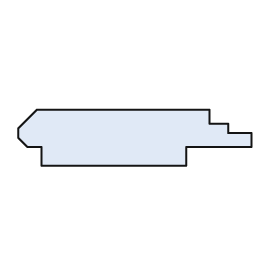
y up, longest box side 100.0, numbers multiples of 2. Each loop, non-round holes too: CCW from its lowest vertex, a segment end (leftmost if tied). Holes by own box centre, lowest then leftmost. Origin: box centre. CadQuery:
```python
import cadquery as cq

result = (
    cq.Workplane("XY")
    .moveTo(-40.0, -12.0)
    .lineTo(22.0, -12.0)
    .lineTo(22.0, -4.0)
    .lineTo(50.0, -4.0)
    .lineTo(50.0, 2.0)
    .lineTo(40.0, 2.0)
    .lineTo(40.0, 6.0)
    .lineTo(32.0, 6.0)
    .lineTo(32.0, 12.0)
    .lineTo(-42.0, 12.0)
    .lineTo(-50.0, 4.0)
    .lineTo(-50.0, 0.0)
    .lineTo(-46.0, -4.0)
    .lineTo(-40.0, -4.0)
    .close()
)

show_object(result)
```